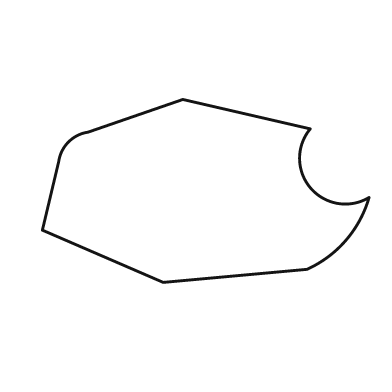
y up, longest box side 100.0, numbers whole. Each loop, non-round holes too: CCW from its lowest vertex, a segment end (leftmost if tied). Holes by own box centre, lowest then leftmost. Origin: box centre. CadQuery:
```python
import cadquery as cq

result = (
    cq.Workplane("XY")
    .moveTo(-13.0, -28.0)
    .lineTo(31.0, -24.0)
    .threePointArc((43.0, -15.0), (50.0, -2.0))
    .threePointArc((32.0, 1.0), (32.0, 19.0))
    .lineTo(-7.0, 28.0)
    .lineTo(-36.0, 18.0)
    .threePointArc((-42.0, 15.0), (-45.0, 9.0))
    .lineTo(-50.0, -12.0)
    .close()
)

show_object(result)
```